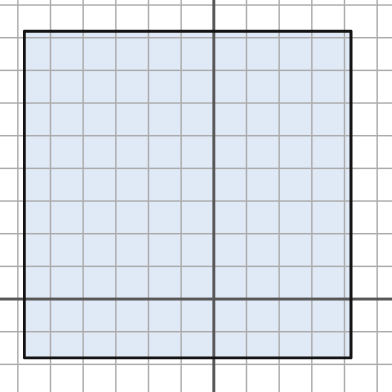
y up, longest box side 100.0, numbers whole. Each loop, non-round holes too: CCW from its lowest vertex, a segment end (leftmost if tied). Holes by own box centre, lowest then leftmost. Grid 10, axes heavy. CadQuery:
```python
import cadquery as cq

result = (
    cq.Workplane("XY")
    .moveTo(-58.0, -18.0)
    .lineTo(42.0, -18.0)
    .lineTo(42.0, 82.0)
    .lineTo(-58.0, 82.0)
    .close()
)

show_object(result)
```